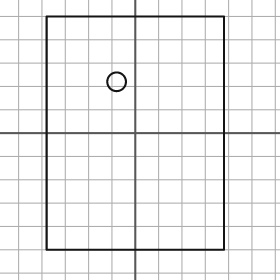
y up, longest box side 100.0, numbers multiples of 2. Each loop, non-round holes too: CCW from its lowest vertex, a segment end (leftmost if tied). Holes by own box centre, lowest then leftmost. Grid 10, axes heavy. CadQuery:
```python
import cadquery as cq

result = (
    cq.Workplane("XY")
    .moveTo(-38.0, -50.0)
    .lineTo(38.0, -50.0)
    .lineTo(38.0, 50.0)
    .lineTo(-38.0, 50.0)
    .close()
    .moveTo(-8.0, 22.0)
    .circle(4.0)
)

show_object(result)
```